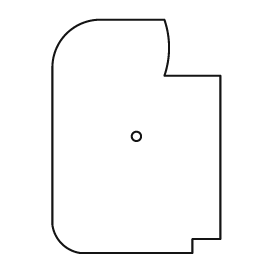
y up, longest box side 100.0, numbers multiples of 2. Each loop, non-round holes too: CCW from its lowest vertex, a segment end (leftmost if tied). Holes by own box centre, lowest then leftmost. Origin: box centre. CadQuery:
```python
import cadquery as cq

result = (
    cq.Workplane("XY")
    .moveTo(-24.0, -50.0)
    .lineTo(24.0, -50.0)
    .lineTo(24.0, -44.0)
    .lineTo(36.0, -44.0)
    .lineTo(36.0, 26.0)
    .lineTo(12.0, 26.0)
    .threePointArc((14.0, 38.0), (12.0, 50.0))
    .lineTo(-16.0, 50.0)
    .threePointArc((-30.0, 44.0), (-36.0, 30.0))
    .lineTo(-36.0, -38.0)
    .threePointArc((-32.0, -46.0), (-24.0, -50.0))
    .close()
    .moveTo(0.0, 0.0)
    .circle(2.0)
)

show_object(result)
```